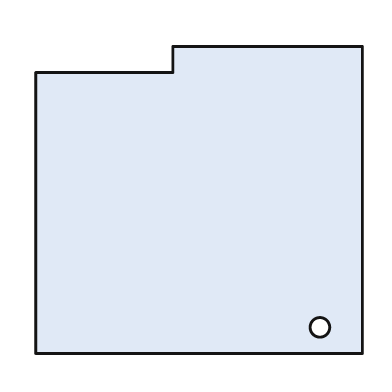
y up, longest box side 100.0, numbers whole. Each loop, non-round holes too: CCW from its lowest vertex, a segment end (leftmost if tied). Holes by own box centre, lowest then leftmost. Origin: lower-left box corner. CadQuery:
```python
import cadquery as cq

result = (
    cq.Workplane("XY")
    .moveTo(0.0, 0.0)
    .lineTo(100.0, 0.0)
    .lineTo(100.0, 94.0)
    .lineTo(42.0, 94.0)
    .lineTo(42.0, 86.0)
    .lineTo(0.0, 86.0)
    .close()
    .moveTo(87.0, 8.0)
    .circle(3.0)
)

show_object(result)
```